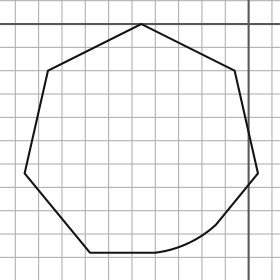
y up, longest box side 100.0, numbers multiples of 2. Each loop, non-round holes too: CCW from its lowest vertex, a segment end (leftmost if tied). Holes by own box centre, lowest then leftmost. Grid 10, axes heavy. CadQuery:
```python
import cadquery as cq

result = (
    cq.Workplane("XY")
    .moveTo(-68.0, -98.0)
    .lineTo(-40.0, -98.0)
    .threePointArc((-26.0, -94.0), (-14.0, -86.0))
    .lineTo(4.0, -64.0)
    .lineTo(-6.0, -20.0)
    .lineTo(-46.0, 0.0)
    .lineTo(-86.0, -20.0)
    .lineTo(-96.0, -64.0)
    .close()
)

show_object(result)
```